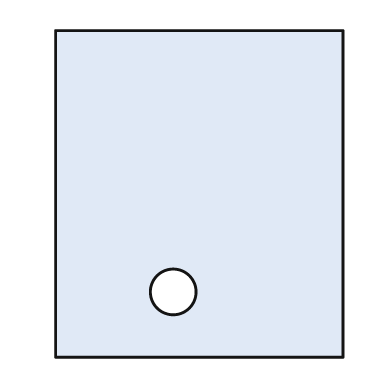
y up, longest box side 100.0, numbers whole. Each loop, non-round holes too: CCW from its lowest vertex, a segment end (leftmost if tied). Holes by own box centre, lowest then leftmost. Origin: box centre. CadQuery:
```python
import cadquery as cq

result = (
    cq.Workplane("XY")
    .moveTo(-44.0, -50.0)
    .lineTo(44.0, -50.0)
    .lineTo(44.0, 50.0)
    .lineTo(-44.0, 50.0)
    .close()
    .moveTo(-8.0, -30.0)
    .circle(7.0)
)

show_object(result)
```